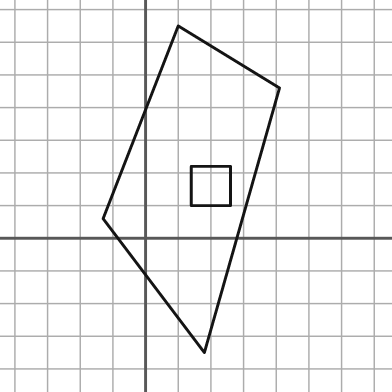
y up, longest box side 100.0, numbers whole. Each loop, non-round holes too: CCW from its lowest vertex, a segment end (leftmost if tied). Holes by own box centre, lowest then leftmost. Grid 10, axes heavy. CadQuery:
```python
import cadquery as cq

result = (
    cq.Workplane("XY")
    .moveTo(18.0, -35.0)
    .lineTo(41.0, 46.0)
    .lineTo(10.0, 65.0)
    .lineTo(-13.0, 6.0)
    .close()
    .moveTo(14.0, 10.0)
    .lineTo(26.0, 10.0)
    .lineTo(26.0, 22.0)
    .lineTo(14.0, 22.0)
    .close()
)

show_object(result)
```